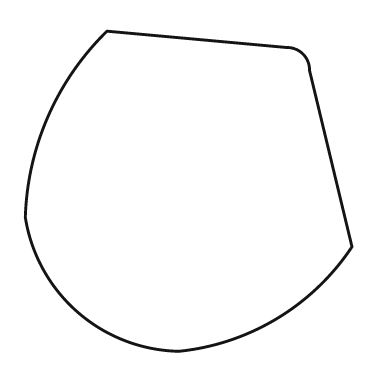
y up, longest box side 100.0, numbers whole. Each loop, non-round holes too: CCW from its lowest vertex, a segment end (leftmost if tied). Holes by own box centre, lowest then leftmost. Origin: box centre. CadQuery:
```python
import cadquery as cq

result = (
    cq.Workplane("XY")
    .moveTo(-3.0, -49.0)
    .threePointArc((27.0, -39.0), (50.0, -17.0))
    .lineTo(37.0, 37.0)
    .threePointArc((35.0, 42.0), (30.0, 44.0))
    .lineTo(-25.0, 49.0)
    .threePointArc((-43.0, 23.0), (-50.0, -8.0))
    .threePointArc((-34.0, -37.0), (-3.0, -49.0))
    .close()
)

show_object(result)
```